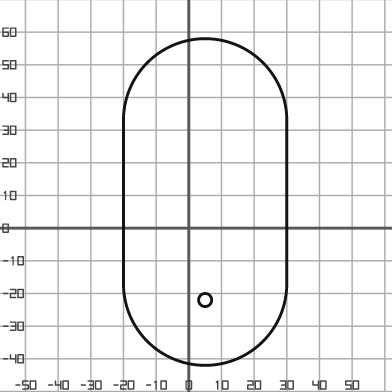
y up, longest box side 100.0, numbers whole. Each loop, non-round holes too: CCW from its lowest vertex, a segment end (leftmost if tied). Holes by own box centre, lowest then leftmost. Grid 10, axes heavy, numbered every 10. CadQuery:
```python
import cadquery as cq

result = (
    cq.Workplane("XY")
    .moveTo(-20.0, -17.0)
    .threePointArc((5.0, -42.0), (30.0, -17.0))
    .lineTo(30.0, 33.0)
    .threePointArc((5.0, 58.0), (-20.0, 33.0))
    .close()
    .moveTo(5.0, -22.0)
    .circle(2.0)
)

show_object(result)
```